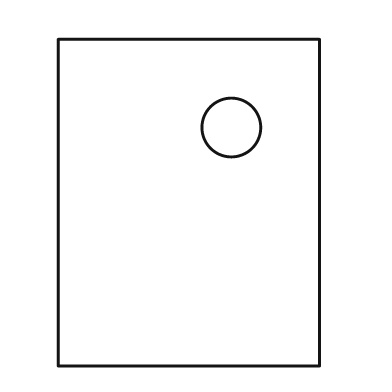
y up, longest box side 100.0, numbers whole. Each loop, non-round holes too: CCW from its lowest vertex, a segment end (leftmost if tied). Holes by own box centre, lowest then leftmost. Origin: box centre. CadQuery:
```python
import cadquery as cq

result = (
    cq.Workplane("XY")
    .moveTo(-40.0, -50.0)
    .lineTo(40.0, -50.0)
    .lineTo(40.0, 50.0)
    .lineTo(-40.0, 50.0)
    .close()
    .moveTo(13.0, 23.0)
    .circle(9.0)
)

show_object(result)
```